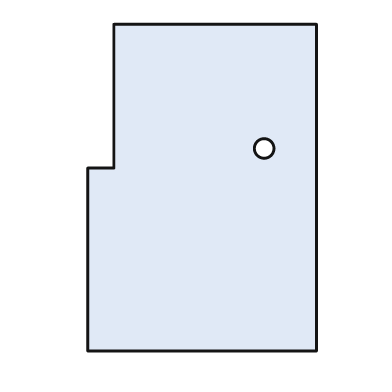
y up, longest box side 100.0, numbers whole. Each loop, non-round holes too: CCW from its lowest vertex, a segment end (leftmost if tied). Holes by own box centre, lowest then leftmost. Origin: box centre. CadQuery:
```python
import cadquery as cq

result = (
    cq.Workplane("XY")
    .moveTo(-35.0, -50.0)
    .lineTo(35.0, -50.0)
    .lineTo(35.0, 50.0)
    .lineTo(-27.0, 50.0)
    .lineTo(-27.0, 6.0)
    .lineTo(-35.0, 6.0)
    .close()
    .moveTo(19.0, 12.0)
    .circle(3.0)
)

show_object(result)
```